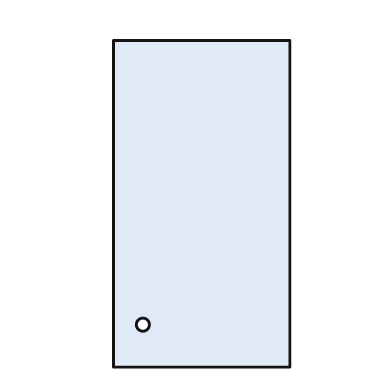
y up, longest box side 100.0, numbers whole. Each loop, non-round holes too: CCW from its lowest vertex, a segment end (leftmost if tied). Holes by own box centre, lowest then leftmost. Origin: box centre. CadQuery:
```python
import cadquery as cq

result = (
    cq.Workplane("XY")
    .moveTo(-27.0, -50.0)
    .lineTo(27.0, -50.0)
    .lineTo(27.0, 50.0)
    .lineTo(-27.0, 50.0)
    .close()
    .moveTo(-18.0, -37.0)
    .circle(2.0)
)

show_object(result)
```